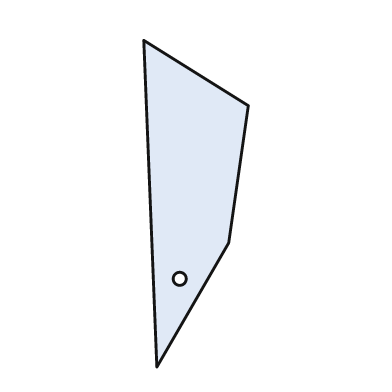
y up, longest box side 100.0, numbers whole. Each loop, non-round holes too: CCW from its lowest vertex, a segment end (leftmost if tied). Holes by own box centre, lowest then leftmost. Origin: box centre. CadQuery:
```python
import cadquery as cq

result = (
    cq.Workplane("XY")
    .moveTo(-12.0, -50.0)
    .lineTo(10.0, -12.0)
    .lineTo(16.0, 30.0)
    .lineTo(-16.0, 50.0)
    .close()
    .moveTo(-5.0, -23.0)
    .circle(2.0)
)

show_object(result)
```